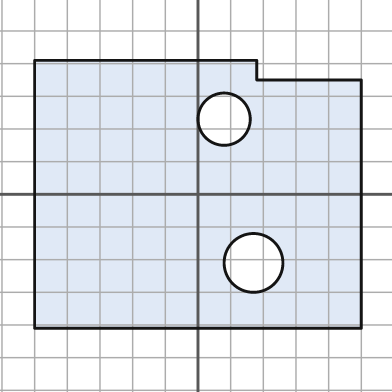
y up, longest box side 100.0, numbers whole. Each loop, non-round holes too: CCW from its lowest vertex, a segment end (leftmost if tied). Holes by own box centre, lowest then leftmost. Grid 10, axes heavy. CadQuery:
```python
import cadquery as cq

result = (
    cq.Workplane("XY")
    .moveTo(-50.0, -41.0)
    .lineTo(50.0, -41.0)
    .lineTo(50.0, 35.0)
    .lineTo(18.0, 35.0)
    .lineTo(18.0, 41.0)
    .lineTo(-50.0, 41.0)
    .close()
    .moveTo(17.0, -21.0)
    .circle(9.0)
    .moveTo(8.0, 23.0)
    .circle(8.0)
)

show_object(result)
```